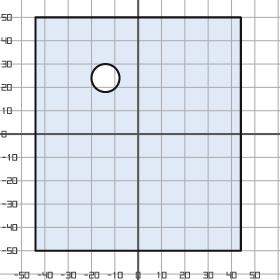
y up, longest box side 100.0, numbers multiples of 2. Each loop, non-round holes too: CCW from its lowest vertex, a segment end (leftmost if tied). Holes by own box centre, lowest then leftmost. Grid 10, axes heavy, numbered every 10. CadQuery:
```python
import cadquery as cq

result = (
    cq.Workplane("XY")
    .moveTo(-44.0, -50.0)
    .lineTo(44.0, -50.0)
    .lineTo(44.0, 50.0)
    .lineTo(-44.0, 50.0)
    .close()
    .moveTo(-14.0, 24.0)
    .circle(6.0)
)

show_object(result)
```